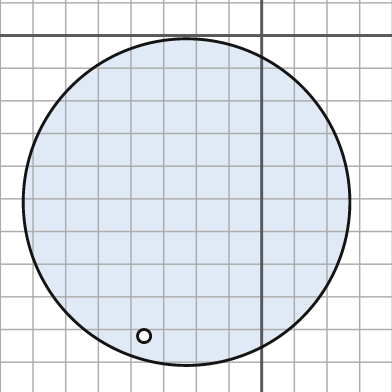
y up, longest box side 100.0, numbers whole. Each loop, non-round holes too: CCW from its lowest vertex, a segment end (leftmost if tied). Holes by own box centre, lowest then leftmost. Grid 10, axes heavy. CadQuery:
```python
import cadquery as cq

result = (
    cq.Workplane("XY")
    .moveTo(-23.0, -51.0)
    .circle(50.0)
    .moveTo(-36.0, -92.0)
    .circle(2.0)
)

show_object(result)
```